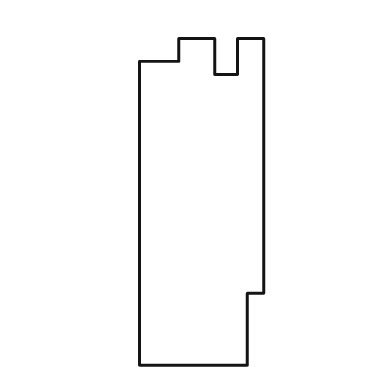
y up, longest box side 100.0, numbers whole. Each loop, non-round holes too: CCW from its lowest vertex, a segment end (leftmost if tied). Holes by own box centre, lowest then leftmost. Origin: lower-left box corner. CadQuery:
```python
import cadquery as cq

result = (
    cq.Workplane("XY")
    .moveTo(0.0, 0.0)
    .lineTo(33.0, 0.0)
    .lineTo(33.0, 22.0)
    .lineTo(38.0, 22.0)
    .lineTo(38.0, 100.0)
    .lineTo(30.0, 100.0)
    .lineTo(30.0, 89.0)
    .lineTo(23.0, 89.0)
    .lineTo(23.0, 100.0)
    .lineTo(12.0, 100.0)
    .lineTo(12.0, 93.0)
    .lineTo(0.0, 93.0)
    .close()
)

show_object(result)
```